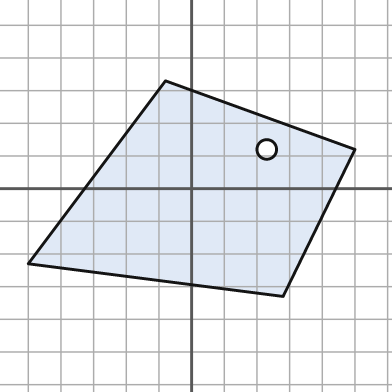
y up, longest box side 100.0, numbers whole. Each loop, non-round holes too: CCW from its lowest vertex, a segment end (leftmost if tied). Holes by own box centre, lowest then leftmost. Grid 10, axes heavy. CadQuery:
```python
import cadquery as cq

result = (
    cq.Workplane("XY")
    .moveTo(28.0, -33.0)
    .lineTo(50.0, 12.0)
    .lineTo(-8.0, 33.0)
    .lineTo(-50.0, -23.0)
    .close()
    .moveTo(23.0, 12.0)
    .circle(3.0)
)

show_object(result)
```